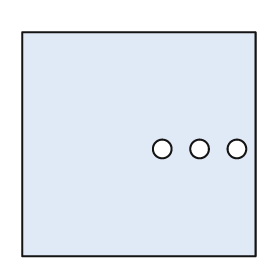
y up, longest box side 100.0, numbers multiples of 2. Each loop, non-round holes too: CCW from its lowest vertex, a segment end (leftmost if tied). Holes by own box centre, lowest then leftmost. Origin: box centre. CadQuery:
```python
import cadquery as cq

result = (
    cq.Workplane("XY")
    .moveTo(-50.0, -48.0)
    .lineTo(50.0, -48.0)
    .lineTo(50.0, 48.0)
    .lineTo(-50.0, 48.0)
    .close()
    .moveTo(10.0, -2.0)
    .circle(4.0)
    .moveTo(26.0, -2.0)
    .circle(4.0)
    .moveTo(42.0, -2.0)
    .circle(4.0)
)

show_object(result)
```